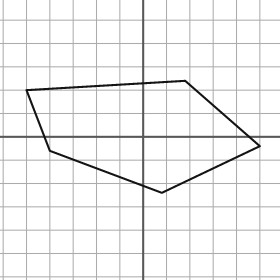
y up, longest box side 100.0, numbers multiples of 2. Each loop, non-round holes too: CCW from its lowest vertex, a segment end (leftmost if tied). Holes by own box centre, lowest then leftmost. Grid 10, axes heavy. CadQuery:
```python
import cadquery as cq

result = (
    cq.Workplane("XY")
    .moveTo(8.0, -24.0)
    .lineTo(50.0, -4.0)
    .lineTo(18.0, 24.0)
    .lineTo(-50.0, 20.0)
    .lineTo(-40.0, -6.0)
    .close()
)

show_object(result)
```